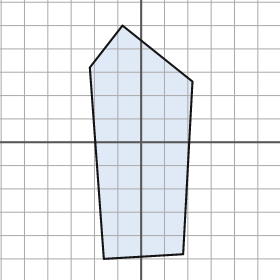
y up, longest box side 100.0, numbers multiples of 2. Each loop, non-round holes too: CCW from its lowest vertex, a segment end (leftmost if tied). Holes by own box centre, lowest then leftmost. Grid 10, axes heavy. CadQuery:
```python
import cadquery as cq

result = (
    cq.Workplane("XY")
    .moveTo(-16.0, -50.0)
    .lineTo(18.0, -48.0)
    .lineTo(22.0, 26.0)
    .lineTo(-8.0, 50.0)
    .lineTo(-22.0, 32.0)
    .close()
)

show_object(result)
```